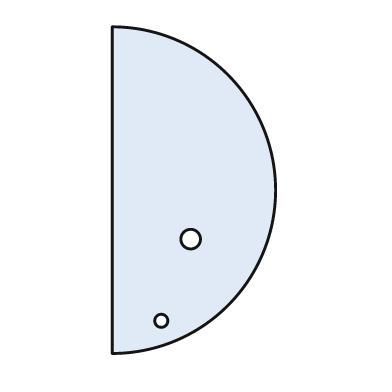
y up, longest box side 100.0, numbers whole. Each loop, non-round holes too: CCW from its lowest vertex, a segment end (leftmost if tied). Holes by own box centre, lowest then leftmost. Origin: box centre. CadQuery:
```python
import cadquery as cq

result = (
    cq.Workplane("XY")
    .moveTo(-25.0, -50.0)
    .threePointArc((25.0, 0.0), (-25.0, 50.0))
    .close()
    .moveTo(-10.0, -40.0)
    .circle(2.0)
    .moveTo(-1.0, -15.0)
    .circle(3.0)
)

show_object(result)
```